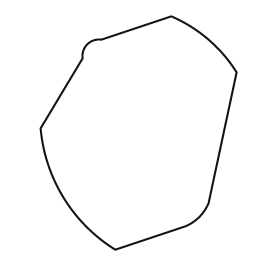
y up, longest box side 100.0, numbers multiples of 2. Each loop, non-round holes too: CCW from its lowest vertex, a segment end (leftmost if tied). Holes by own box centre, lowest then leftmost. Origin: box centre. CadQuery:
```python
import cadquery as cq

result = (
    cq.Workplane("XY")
    .moveTo(-10.0, -50.0)
    .lineTo(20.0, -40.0)
    .threePointArc((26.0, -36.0), (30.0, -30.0))
    .lineTo(42.0, 26.0)
    .threePointArc((30.0, 40.0), (14.0, 50.0))
    .lineTo(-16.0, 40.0)
    .threePointArc((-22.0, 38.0), (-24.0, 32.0))
    .lineTo(-42.0, 2.0)
    .threePointArc((-32.0, -28.0), (-10.0, -50.0))
    .close()
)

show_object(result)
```